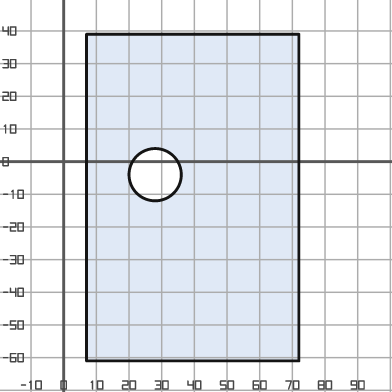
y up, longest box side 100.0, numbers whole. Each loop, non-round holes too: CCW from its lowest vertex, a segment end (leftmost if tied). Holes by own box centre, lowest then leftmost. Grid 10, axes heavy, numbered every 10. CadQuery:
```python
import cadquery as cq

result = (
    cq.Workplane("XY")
    .moveTo(7.0, -61.0)
    .lineTo(72.0, -61.0)
    .lineTo(72.0, 39.0)
    .lineTo(7.0, 39.0)
    .close()
    .moveTo(28.0, -4.0)
    .circle(8.0)
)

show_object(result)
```